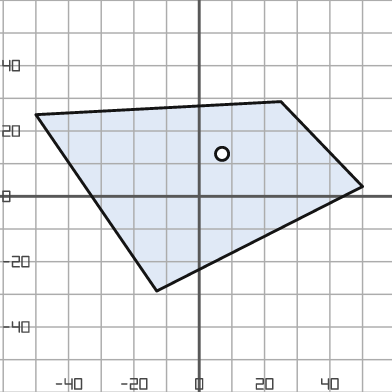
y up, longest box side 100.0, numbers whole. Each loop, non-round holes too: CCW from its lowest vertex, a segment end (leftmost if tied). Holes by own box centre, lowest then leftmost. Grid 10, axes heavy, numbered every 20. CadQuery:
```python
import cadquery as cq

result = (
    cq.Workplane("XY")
    .moveTo(-13.0, -29.0)
    .lineTo(50.0, 3.0)
    .lineTo(25.0, 29.0)
    .lineTo(-50.0, 25.0)
    .close()
    .moveTo(7.0, 13.0)
    .circle(2.0)
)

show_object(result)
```